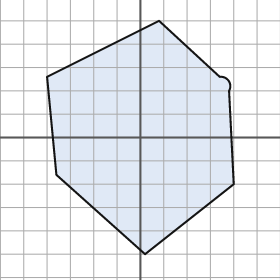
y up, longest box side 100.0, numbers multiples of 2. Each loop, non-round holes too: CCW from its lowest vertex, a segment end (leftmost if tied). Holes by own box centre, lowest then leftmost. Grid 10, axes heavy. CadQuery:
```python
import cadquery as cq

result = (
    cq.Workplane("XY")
    .moveTo(2.0, -50.0)
    .lineTo(40.0, -20.0)
    .lineTo(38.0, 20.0)
    .threePointArc((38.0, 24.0), (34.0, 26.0))
    .lineTo(8.0, 50.0)
    .lineTo(-40.0, 26.0)
    .lineTo(-36.0, -16.0)
    .close()
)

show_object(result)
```